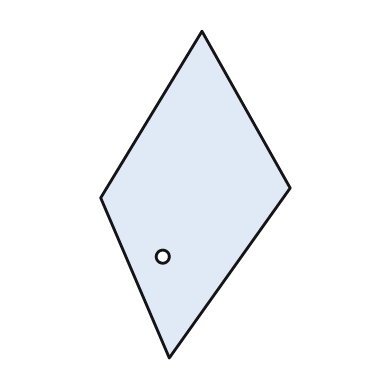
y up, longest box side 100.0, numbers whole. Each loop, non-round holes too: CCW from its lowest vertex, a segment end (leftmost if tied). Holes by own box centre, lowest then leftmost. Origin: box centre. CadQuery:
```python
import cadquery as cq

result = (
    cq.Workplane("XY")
    .moveTo(-8.0, -50.0)
    .lineTo(29.0, 2.0)
    .lineTo(2.0, 50.0)
    .lineTo(-29.0, -1.0)
    .close()
    .moveTo(-10.0, -19.0)
    .circle(2.0)
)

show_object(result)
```